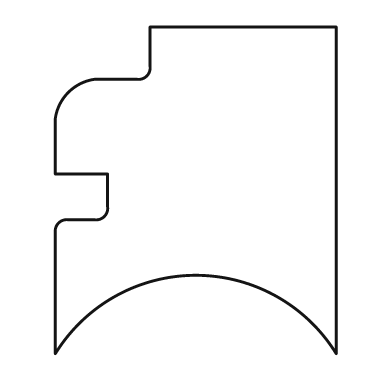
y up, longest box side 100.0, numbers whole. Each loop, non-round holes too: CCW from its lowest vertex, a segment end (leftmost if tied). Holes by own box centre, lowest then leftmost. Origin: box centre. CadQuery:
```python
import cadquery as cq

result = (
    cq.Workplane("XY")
    .moveTo(-43.0, -50.0)
    .threePointArc((0.0, -26.0), (43.0, -50.0))
    .lineTo(43.0, 50.0)
    .lineTo(-14.0, 50.0)
    .lineTo(-14.0, 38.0)
    .threePointArc((-15.0, 35.0), (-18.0, 34.0))
    .lineTo(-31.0, 34.0)
    .threePointArc((-39.0, 30.0), (-43.0, 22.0))
    .lineTo(-43.0, 5.0)
    .lineTo(-27.0, 5.0)
    .lineTo(-27.0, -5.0)
    .threePointArc((-28.0, -8.0), (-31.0, -9.0))
    .lineTo(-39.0, -9.0)
    .threePointArc((-42.0, -10.0), (-43.0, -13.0))
    .close()
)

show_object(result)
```